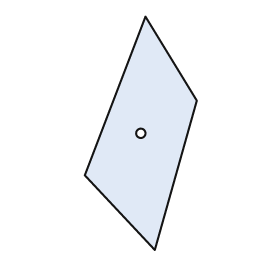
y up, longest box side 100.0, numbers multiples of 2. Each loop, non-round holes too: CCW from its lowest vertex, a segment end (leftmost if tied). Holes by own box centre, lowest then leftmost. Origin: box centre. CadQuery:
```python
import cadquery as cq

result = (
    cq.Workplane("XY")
    .moveTo(6.0, -50.0)
    .lineTo(24.0, 14.0)
    .lineTo(2.0, 50.0)
    .lineTo(-24.0, -18.0)
    .close()
    .moveTo(0.0, 0.0)
    .circle(2.0)
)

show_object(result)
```